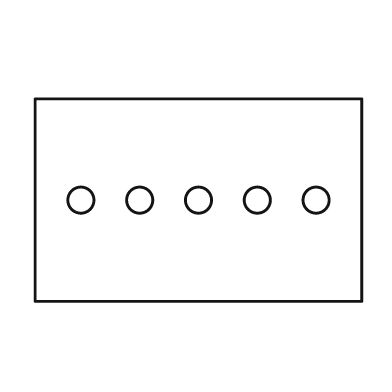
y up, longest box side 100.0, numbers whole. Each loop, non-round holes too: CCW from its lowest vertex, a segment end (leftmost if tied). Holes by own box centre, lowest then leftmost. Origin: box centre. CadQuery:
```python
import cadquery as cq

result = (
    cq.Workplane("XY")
    .moveTo(-50.0, -31.0)
    .lineTo(50.0, -31.0)
    .lineTo(50.0, 31.0)
    .lineTo(-50.0, 31.0)
    .close()
    .moveTo(-36.0, 0.0)
    .circle(4.0)
    .moveTo(-18.0, 0.0)
    .circle(4.0)
    .moveTo(0.0, 0.0)
    .circle(4.0)
    .moveTo(18.0, 0.0)
    .circle(4.0)
    .moveTo(36.0, 0.0)
    .circle(4.0)
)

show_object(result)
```